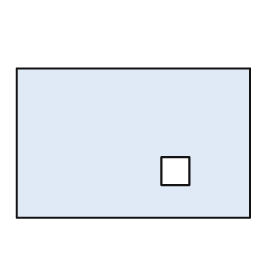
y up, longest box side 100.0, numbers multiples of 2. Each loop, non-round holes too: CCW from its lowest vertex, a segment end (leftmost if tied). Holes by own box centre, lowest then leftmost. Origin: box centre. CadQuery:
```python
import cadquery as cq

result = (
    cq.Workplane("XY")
    .moveTo(-50.0, -32.0)
    .lineTo(50.0, -32.0)
    .lineTo(50.0, 32.0)
    .lineTo(-50.0, 32.0)
    .close()
    .moveTo(12.0, -18.0)
    .lineTo(24.0, -18.0)
    .lineTo(24.0, -6.0)
    .lineTo(12.0, -6.0)
    .close()
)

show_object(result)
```